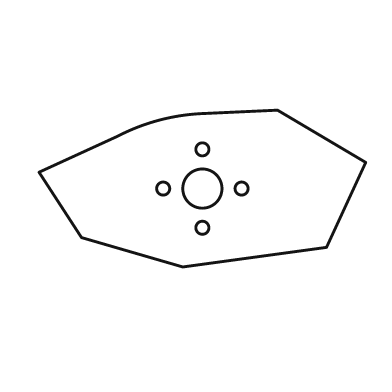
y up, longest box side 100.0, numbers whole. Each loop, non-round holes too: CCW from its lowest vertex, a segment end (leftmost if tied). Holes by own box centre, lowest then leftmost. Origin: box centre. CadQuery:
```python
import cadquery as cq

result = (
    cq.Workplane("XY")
    .moveTo(-6.0, -24.0)
    .lineTo(38.0, -18.0)
    .lineTo(50.0, 8.0)
    .lineTo(23.0, 24.0)
    .lineTo(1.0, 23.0)
    .threePointArc((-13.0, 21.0), (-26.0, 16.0))
    .lineTo(-50.0, 5.0)
    .lineTo(-37.0, -15.0)
    .close()
    .moveTo(0.0, -12.0)
    .circle(2.0)
    .moveTo(-12.0, 0.0)
    .circle(2.0)
    .moveTo(0.0, 0.0)
    .circle(6.0)
    .moveTo(12.0, 0.0)
    .circle(2.0)
    .moveTo(0.0, 12.0)
    .circle(2.0)
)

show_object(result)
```